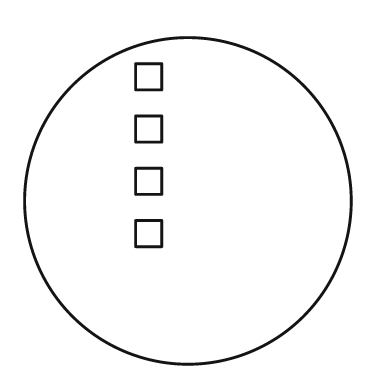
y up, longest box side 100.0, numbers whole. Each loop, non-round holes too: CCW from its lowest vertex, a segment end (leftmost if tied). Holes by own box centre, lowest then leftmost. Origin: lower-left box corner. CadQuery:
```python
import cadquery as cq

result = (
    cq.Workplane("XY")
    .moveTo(50.0, 50.0)
    .circle(50.0)
    .moveTo(34.0, 36.0)
    .lineTo(42.0, 36.0)
    .lineTo(42.0, 44.0)
    .lineTo(34.0, 44.0)
    .close()
    .moveTo(34.0, 52.0)
    .lineTo(42.0, 52.0)
    .lineTo(42.0, 60.0)
    .lineTo(34.0, 60.0)
    .close()
    .moveTo(34.0, 68.0)
    .lineTo(42.0, 68.0)
    .lineTo(42.0, 76.0)
    .lineTo(34.0, 76.0)
    .close()
    .moveTo(34.0, 84.0)
    .lineTo(42.0, 84.0)
    .lineTo(42.0, 92.0)
    .lineTo(34.0, 92.0)
    .close()
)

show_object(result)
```